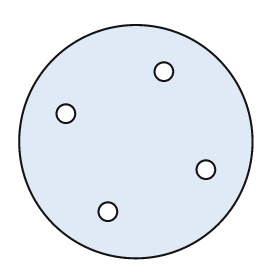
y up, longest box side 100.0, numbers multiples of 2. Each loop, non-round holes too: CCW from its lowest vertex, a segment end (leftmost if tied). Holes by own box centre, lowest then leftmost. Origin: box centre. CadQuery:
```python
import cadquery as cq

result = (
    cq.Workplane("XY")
    .moveTo(0.0, 0.0)
    .circle(50.0)
    .moveTo(-12.0, -30.0)
    .circle(4.0)
    .moveTo(30.0, -12.0)
    .circle(4.0)
    .moveTo(-30.0, 12.0)
    .circle(4.0)
    .moveTo(12.0, 30.0)
    .circle(4.0)
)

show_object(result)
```